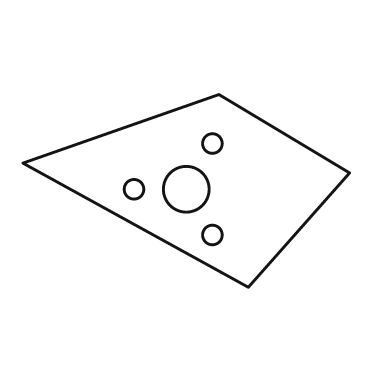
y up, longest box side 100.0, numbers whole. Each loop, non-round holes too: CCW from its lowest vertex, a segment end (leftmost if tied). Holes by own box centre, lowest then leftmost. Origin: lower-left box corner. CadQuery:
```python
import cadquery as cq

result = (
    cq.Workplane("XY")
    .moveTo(69.0, 0.0)
    .lineTo(100.0, 35.0)
    .lineTo(60.0, 59.0)
    .lineTo(0.0, 38.0)
    .close()
    .moveTo(58.0, 16.0)
    .circle(3.0)
    .moveTo(34.0, 30.0)
    .circle(3.0)
    .moveTo(50.0, 30.0)
    .circle(7.0)
    .moveTo(58.0, 44.0)
    .circle(3.0)
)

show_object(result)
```